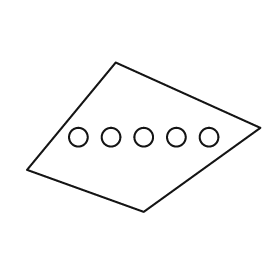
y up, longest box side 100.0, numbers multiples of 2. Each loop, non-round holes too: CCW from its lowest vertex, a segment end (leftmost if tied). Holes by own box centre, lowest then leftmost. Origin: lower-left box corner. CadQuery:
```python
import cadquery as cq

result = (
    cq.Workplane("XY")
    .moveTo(50.0, 0.0)
    .lineTo(100.0, 36.0)
    .lineTo(38.0, 64.0)
    .lineTo(0.0, 18.0)
    .close()
    .moveTo(22.0, 32.0)
    .circle(4.0)
    .moveTo(36.0, 32.0)
    .circle(4.0)
    .moveTo(50.0, 32.0)
    .circle(4.0)
    .moveTo(64.0, 32.0)
    .circle(4.0)
    .moveTo(78.0, 32.0)
    .circle(4.0)
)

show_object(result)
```